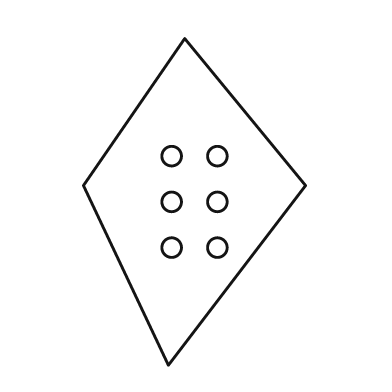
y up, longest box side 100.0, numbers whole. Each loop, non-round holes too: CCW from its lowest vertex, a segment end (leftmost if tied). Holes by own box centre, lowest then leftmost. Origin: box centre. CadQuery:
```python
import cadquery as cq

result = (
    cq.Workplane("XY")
    .moveTo(-8.0, -50.0)
    .lineTo(34.0, 5.0)
    .lineTo(-3.0, 50.0)
    .lineTo(-34.0, 5.0)
    .close()
    .moveTo(-7.0, -14.0)
    .circle(3.0)
    .moveTo(7.0, -14.0)
    .circle(3.0)
    .moveTo(-7.0, 0.0)
    .circle(3.0)
    .moveTo(7.0, 0.0)
    .circle(3.0)
    .moveTo(-7.0, 14.0)
    .circle(3.0)
    .moveTo(7.0, 14.0)
    .circle(3.0)
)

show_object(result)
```